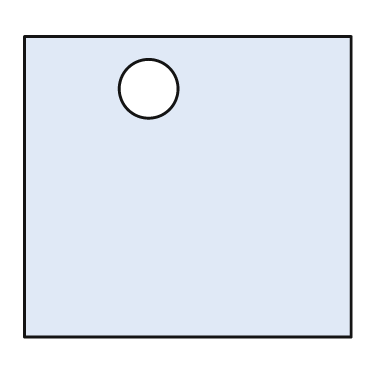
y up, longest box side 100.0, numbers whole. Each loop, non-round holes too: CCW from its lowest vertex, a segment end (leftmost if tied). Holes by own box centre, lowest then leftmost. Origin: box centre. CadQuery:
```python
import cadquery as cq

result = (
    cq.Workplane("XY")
    .moveTo(-50.0, -46.0)
    .lineTo(50.0, -46.0)
    .lineTo(50.0, 46.0)
    .lineTo(-50.0, 46.0)
    .close()
    .moveTo(-12.0, 30.0)
    .circle(9.0)
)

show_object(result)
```